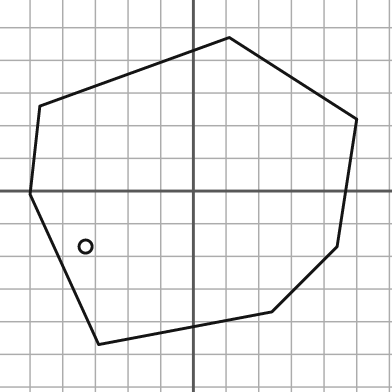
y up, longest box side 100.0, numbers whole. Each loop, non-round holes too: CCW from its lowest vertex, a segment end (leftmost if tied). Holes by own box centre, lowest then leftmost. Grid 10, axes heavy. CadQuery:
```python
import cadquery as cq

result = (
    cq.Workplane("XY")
    .moveTo(-29.0, -47.0)
    .lineTo(24.0, -37.0)
    .lineTo(44.0, -17.0)
    .lineTo(50.0, 22.0)
    .lineTo(11.0, 47.0)
    .lineTo(-47.0, 26.0)
    .lineTo(-50.0, -1.0)
    .close()
    .moveTo(-33.0, -17.0)
    .circle(2.0)
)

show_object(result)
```